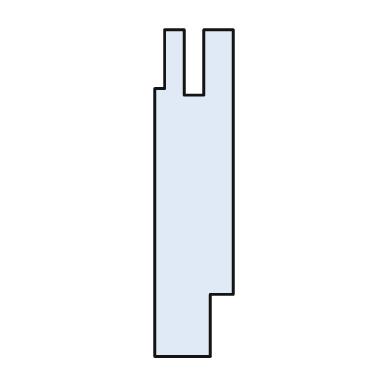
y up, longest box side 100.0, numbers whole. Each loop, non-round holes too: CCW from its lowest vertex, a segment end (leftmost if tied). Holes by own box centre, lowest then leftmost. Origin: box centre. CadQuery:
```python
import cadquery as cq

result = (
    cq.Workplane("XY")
    .moveTo(-12.0, -50.0)
    .lineTo(5.0, -50.0)
    .lineTo(5.0, -31.0)
    .lineTo(12.0, -31.0)
    .lineTo(12.0, 50.0)
    .lineTo(3.0, 50.0)
    .lineTo(3.0, 30.0)
    .lineTo(-3.0, 30.0)
    .lineTo(-3.0, 50.0)
    .lineTo(-9.0, 50.0)
    .lineTo(-9.0, 32.0)
    .lineTo(-12.0, 32.0)
    .close()
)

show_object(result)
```